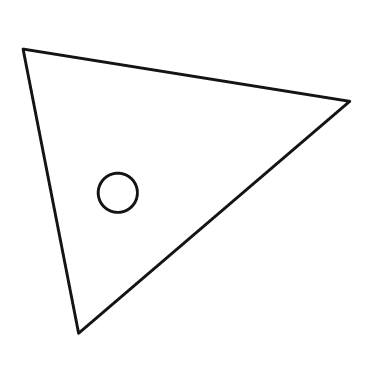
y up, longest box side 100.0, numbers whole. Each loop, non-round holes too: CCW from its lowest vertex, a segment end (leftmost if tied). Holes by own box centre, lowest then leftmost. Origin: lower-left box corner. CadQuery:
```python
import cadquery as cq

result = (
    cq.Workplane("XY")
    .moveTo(17.0, 0.0)
    .lineTo(100.0, 71.0)
    .lineTo(0.0, 87.0)
    .close()
    .moveTo(29.0, 43.0)
    .circle(6.0)
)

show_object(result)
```